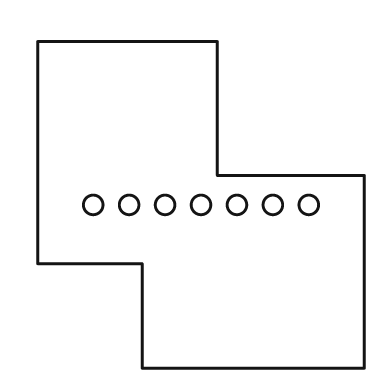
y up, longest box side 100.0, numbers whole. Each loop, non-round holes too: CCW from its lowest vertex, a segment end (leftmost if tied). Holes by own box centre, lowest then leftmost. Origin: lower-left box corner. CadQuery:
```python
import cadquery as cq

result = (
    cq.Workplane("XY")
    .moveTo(32.0, 0.0)
    .lineTo(100.0, 0.0)
    .lineTo(100.0, 59.0)
    .lineTo(55.0, 59.0)
    .lineTo(55.0, 100.0)
    .lineTo(0.0, 100.0)
    .lineTo(0.0, 32.0)
    .lineTo(32.0, 32.0)
    .close()
    .moveTo(17.0, 50.0)
    .circle(3.0)
    .moveTo(28.0, 50.0)
    .circle(3.0)
    .moveTo(39.0, 50.0)
    .circle(3.0)
    .moveTo(50.0, 50.0)
    .circle(3.0)
    .moveTo(61.0, 50.0)
    .circle(3.0)
    .moveTo(72.0, 50.0)
    .circle(3.0)
    .moveTo(83.0, 50.0)
    .circle(3.0)
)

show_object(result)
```